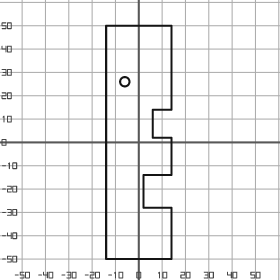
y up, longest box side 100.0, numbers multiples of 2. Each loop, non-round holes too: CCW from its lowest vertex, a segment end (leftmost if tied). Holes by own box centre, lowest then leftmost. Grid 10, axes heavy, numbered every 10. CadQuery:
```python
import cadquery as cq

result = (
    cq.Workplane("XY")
    .moveTo(-14.0, -50.0)
    .lineTo(14.0, -50.0)
    .lineTo(14.0, -28.0)
    .lineTo(2.0, -28.0)
    .lineTo(2.0, -14.0)
    .lineTo(14.0, -14.0)
    .lineTo(14.0, 2.0)
    .lineTo(6.0, 2.0)
    .lineTo(6.0, 14.0)
    .lineTo(14.0, 14.0)
    .lineTo(14.0, 50.0)
    .lineTo(-14.0, 50.0)
    .close()
    .moveTo(-6.0, 26.0)
    .circle(2.0)
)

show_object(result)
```